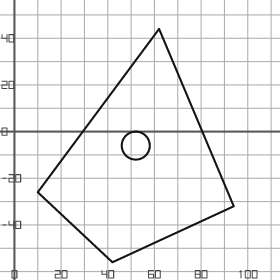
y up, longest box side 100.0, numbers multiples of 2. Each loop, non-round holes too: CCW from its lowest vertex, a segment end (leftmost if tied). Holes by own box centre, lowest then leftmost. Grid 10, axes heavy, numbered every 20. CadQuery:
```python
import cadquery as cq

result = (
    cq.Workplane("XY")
    .moveTo(42.0, -56.0)
    .lineTo(94.0, -32.0)
    .lineTo(62.0, 44.0)
    .lineTo(10.0, -26.0)
    .close()
    .moveTo(52.0, -6.0)
    .circle(6.0)
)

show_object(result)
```